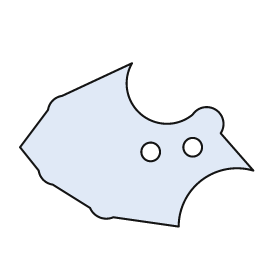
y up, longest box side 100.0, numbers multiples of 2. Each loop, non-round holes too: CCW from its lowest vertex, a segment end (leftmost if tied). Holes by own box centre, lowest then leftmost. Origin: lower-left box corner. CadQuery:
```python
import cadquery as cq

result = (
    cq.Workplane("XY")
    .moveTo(68.0, 0.0)
    .threePointArc((78.0, 20.0), (100.0, 24.0))
    .lineTo(86.0, 40.0)
    .threePointArc((84.0, 50.0), (74.0, 48.0))
    .threePointArc((52.0, 48.0), (48.0, 70.0))
    .lineTo(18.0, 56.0)
    .threePointArc((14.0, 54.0), (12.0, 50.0))
    .lineTo(0.0, 34.0)
    .lineTo(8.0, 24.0)
    .threePointArc((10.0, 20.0), (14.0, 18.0))
    .lineTo(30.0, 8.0)
    .threePointArc((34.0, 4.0), (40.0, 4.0))
    .close()
    .moveTo(56.0, 32.0)
    .circle(4.0)
    .moveTo(74.0, 34.0)
    .circle(4.0)
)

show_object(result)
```